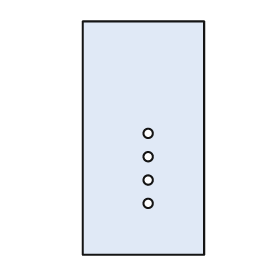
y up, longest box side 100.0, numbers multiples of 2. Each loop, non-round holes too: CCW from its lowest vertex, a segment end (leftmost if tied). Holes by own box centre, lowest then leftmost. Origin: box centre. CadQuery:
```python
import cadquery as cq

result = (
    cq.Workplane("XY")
    .moveTo(-26.0, -50.0)
    .lineTo(26.0, -50.0)
    .lineTo(26.0, 50.0)
    .lineTo(-26.0, 50.0)
    .close()
    .moveTo(2.0, -28.0)
    .circle(2.0)
    .moveTo(2.0, -18.0)
    .circle(2.0)
    .moveTo(2.0, -8.0)
    .circle(2.0)
    .moveTo(2.0, 2.0)
    .circle(2.0)
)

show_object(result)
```